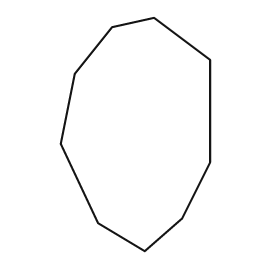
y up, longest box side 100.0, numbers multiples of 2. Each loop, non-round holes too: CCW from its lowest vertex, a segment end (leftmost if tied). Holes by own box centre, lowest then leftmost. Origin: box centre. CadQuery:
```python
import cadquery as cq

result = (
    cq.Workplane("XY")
    .moveTo(4.0, -50.0)
    .lineTo(20.0, -36.0)
    .lineTo(32.0, -12.0)
    .lineTo(32.0, 32.0)
    .lineTo(8.0, 50.0)
    .lineTo(-10.0, 46.0)
    .lineTo(-26.0, 26.0)
    .lineTo(-32.0, -4.0)
    .lineTo(-16.0, -38.0)
    .close()
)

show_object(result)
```